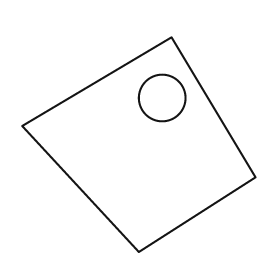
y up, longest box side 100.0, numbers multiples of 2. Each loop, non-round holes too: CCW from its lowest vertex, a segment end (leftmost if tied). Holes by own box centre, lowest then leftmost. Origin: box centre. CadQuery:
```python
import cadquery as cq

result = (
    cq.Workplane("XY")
    .moveTo(0.0, -46.0)
    .lineTo(50.0, -14.0)
    .lineTo(14.0, 46.0)
    .lineTo(-50.0, 8.0)
    .close()
    .moveTo(10.0, 20.0)
    .circle(10.0)
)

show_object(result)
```